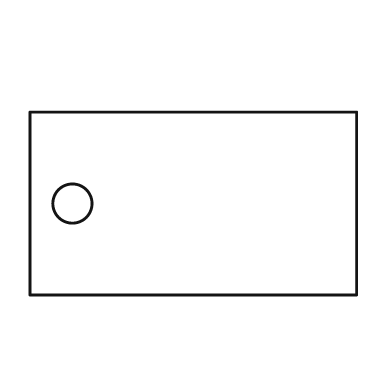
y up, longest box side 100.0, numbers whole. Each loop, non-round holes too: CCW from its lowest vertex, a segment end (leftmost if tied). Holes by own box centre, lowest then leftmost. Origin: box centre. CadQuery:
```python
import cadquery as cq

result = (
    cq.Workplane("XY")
    .moveTo(-50.0, -28.0)
    .lineTo(50.0, -28.0)
    .lineTo(50.0, 28.0)
    .lineTo(-50.0, 28.0)
    .close()
    .moveTo(-37.0, 0.0)
    .circle(6.0)
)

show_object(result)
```